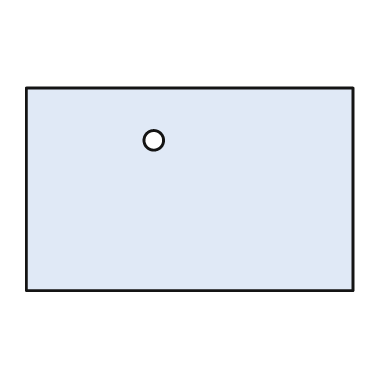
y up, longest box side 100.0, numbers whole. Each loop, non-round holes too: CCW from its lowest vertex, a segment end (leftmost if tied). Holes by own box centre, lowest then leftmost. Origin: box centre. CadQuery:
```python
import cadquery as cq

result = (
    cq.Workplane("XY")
    .moveTo(-50.0, -31.0)
    .lineTo(50.0, -31.0)
    .lineTo(50.0, 31.0)
    .lineTo(-50.0, 31.0)
    .close()
    .moveTo(-11.0, 15.0)
    .circle(3.0)
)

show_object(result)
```